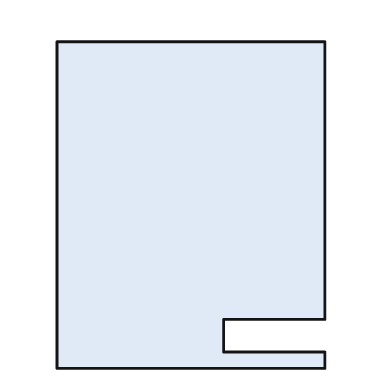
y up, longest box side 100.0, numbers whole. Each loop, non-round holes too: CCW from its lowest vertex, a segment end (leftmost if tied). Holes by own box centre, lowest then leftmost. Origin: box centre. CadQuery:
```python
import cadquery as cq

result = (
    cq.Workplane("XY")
    .moveTo(-41.0, -50.0)
    .lineTo(41.0, -50.0)
    .lineTo(41.0, -45.0)
    .lineTo(10.0, -45.0)
    .lineTo(10.0, -35.0)
    .lineTo(41.0, -35.0)
    .lineTo(41.0, 50.0)
    .lineTo(-41.0, 50.0)
    .close()
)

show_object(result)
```